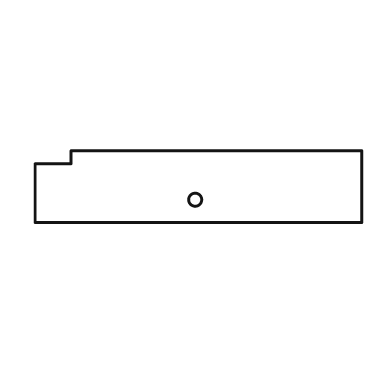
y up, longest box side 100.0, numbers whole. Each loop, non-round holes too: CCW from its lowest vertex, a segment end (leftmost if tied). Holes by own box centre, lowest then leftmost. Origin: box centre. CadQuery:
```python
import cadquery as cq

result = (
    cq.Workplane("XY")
    .moveTo(-50.0, -11.0)
    .lineTo(50.0, -11.0)
    .lineTo(50.0, 11.0)
    .lineTo(-39.0, 11.0)
    .lineTo(-39.0, 7.0)
    .lineTo(-50.0, 7.0)
    .close()
    .moveTo(-1.0, -4.0)
    .circle(2.0)
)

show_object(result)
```